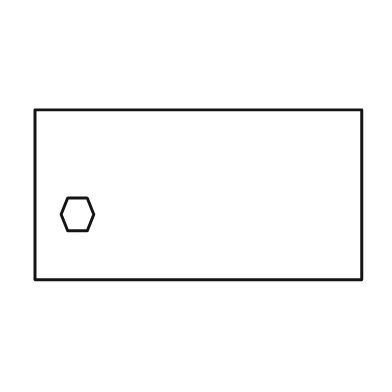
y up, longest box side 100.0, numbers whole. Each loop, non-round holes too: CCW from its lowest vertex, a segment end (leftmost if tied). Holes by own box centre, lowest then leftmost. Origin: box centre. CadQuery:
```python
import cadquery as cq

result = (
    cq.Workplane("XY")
    .moveTo(-50.0, -26.0)
    .lineTo(50.0, -26.0)
    .lineTo(50.0, 26.0)
    .lineTo(-50.0, 26.0)
    .close()
    .moveTo(-40.0, -11.0)
    .lineTo(-34.0, -11.0)
    .lineTo(-32.0, -6.0)
    .lineTo(-34.0, -1.0)
    .lineTo(-40.0, -1.0)
    .lineTo(-42.0, -6.0)
    .close()
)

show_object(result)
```